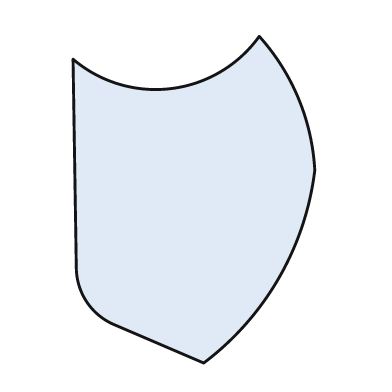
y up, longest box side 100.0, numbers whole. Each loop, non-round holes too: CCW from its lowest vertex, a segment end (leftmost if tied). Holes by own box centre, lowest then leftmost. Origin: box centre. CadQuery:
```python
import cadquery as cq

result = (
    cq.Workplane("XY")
    .moveTo(3.0, -50.0)
    .threePointArc((26.0, -24.0), (37.0, 9.0))
    .threePointArc((32.0, 31.0), (20.0, 50.0))
    .threePointArc((-7.0, 34.0), (-37.0, 43.0))
    .lineTo(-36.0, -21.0)
    .threePointArc((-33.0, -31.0), (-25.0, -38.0))
    .close()
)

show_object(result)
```